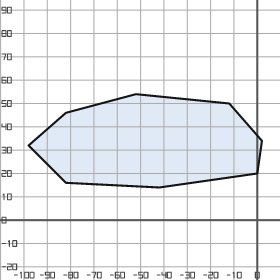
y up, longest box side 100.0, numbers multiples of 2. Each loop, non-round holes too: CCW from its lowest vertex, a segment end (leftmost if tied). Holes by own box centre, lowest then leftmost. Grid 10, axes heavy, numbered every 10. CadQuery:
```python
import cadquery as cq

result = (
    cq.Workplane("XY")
    .moveTo(-42.0, 14.0)
    .lineTo(0.0, 20.0)
    .lineTo(2.0, 34.0)
    .lineTo(-12.0, 50.0)
    .lineTo(-52.0, 54.0)
    .lineTo(-82.0, 46.0)
    .lineTo(-98.0, 32.0)
    .lineTo(-82.0, 16.0)
    .close()
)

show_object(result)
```